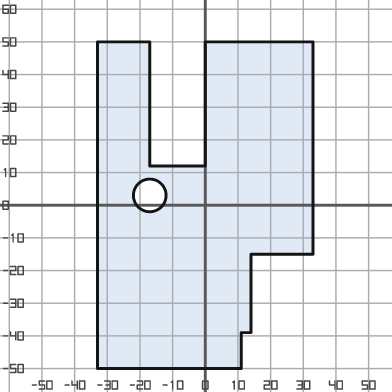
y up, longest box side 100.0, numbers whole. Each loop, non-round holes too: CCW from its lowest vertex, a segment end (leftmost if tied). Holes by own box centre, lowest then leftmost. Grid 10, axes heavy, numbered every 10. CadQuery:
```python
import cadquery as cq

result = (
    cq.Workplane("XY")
    .moveTo(-33.0, -50.0)
    .lineTo(11.0, -50.0)
    .lineTo(11.0, -39.0)
    .lineTo(14.0, -39.0)
    .lineTo(14.0, -15.0)
    .lineTo(33.0, -15.0)
    .lineTo(33.0, 50.0)
    .lineTo(0.0, 50.0)
    .lineTo(0.0, 12.0)
    .lineTo(-17.0, 12.0)
    .lineTo(-17.0, 50.0)
    .lineTo(-33.0, 50.0)
    .close()
    .moveTo(-17.0, 3.0)
    .circle(5.0)
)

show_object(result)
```